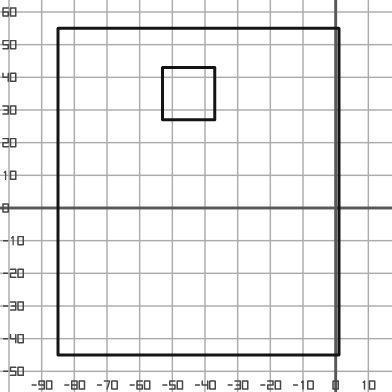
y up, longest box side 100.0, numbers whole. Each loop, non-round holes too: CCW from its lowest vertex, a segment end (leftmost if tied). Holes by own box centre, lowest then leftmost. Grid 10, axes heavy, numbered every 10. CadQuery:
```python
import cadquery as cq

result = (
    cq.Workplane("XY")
    .moveTo(-85.0, -45.0)
    .lineTo(1.0, -45.0)
    .lineTo(1.0, 55.0)
    .lineTo(-85.0, 55.0)
    .close()
    .moveTo(-53.0, 27.0)
    .lineTo(-37.0, 27.0)
    .lineTo(-37.0, 43.0)
    .lineTo(-53.0, 43.0)
    .close()
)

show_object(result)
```